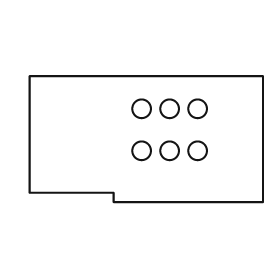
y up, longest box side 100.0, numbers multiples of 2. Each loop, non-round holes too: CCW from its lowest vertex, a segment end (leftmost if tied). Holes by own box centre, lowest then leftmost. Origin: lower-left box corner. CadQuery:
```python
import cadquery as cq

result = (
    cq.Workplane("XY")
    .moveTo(36.0, 0.0)
    .lineTo(100.0, 0.0)
    .lineTo(100.0, 54.0)
    .lineTo(0.0, 54.0)
    .lineTo(0.0, 4.0)
    .lineTo(36.0, 4.0)
    .close()
    .moveTo(48.0, 22.0)
    .circle(4.0)
    .moveTo(60.0, 22.0)
    .circle(4.0)
    .moveTo(72.0, 22.0)
    .circle(4.0)
    .moveTo(48.0, 40.0)
    .circle(4.0)
    .moveTo(60.0, 40.0)
    .circle(4.0)
    .moveTo(72.0, 40.0)
    .circle(4.0)
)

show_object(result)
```